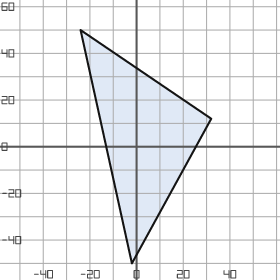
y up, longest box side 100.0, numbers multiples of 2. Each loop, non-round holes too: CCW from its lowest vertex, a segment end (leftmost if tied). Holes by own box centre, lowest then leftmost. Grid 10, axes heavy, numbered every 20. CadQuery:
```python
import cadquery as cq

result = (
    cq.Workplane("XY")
    .moveTo(-2.0, -50.0)
    .lineTo(32.0, 12.0)
    .lineTo(-24.0, 50.0)
    .close()
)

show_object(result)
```